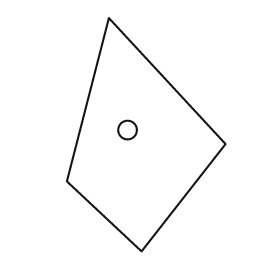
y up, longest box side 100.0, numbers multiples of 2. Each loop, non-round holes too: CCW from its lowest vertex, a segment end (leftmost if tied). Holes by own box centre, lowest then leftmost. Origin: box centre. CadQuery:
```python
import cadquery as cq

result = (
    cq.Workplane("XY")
    .moveTo(-2.0, -50.0)
    .lineTo(34.0, -4.0)
    .lineTo(-16.0, 50.0)
    .lineTo(-34.0, -20.0)
    .close()
    .moveTo(-8.0, 2.0)
    .circle(4.0)
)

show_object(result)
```